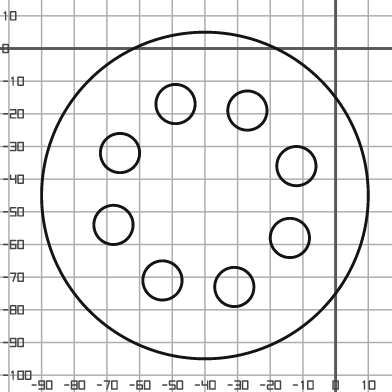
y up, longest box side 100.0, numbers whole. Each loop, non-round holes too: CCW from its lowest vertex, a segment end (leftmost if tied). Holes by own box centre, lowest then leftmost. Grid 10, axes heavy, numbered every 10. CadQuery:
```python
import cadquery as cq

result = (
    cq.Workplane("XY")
    .moveTo(-40.0, -45.0)
    .circle(50.0)
    .moveTo(-31.0, -73.0)
    .circle(6.0)
    .moveTo(-53.0, -71.0)
    .circle(6.0)
    .moveTo(-14.0, -58.0)
    .circle(6.0)
    .moveTo(-68.0, -54.0)
    .circle(6.0)
    .moveTo(-12.0, -36.0)
    .circle(6.0)
    .moveTo(-66.0, -32.0)
    .circle(6.0)
    .moveTo(-27.0, -19.0)
    .circle(6.0)
    .moveTo(-49.0, -17.0)
    .circle(6.0)
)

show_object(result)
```